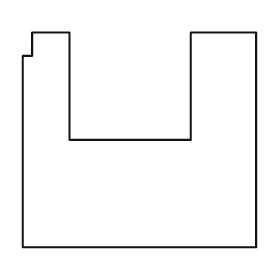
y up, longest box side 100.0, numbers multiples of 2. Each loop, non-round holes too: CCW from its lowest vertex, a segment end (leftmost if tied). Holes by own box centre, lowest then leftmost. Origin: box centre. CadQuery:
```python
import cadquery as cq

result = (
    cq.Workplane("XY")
    .moveTo(-50.0, -46.0)
    .lineTo(50.0, -46.0)
    .lineTo(50.0, 46.0)
    .lineTo(22.0, 46.0)
    .lineTo(22.0, 0.0)
    .lineTo(-30.0, 0.0)
    .lineTo(-30.0, 46.0)
    .lineTo(-46.0, 46.0)
    .lineTo(-46.0, 36.0)
    .lineTo(-50.0, 36.0)
    .close()
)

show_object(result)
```